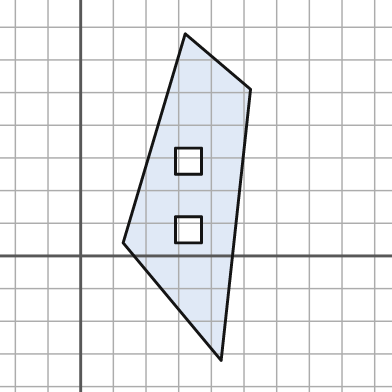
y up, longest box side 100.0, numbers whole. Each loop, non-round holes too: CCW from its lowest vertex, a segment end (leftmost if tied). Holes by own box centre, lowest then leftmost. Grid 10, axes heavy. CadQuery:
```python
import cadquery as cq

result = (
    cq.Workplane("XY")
    .moveTo(43.0, -32.0)
    .lineTo(52.0, 51.0)
    .lineTo(32.0, 68.0)
    .lineTo(13.0, 4.0)
    .close()
    .moveTo(29.0, 4.0)
    .lineTo(37.0, 4.0)
    .lineTo(37.0, 12.0)
    .lineTo(29.0, 12.0)
    .close()
    .moveTo(29.0, 25.0)
    .lineTo(37.0, 25.0)
    .lineTo(37.0, 33.0)
    .lineTo(29.0, 33.0)
    .close()
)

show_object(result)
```